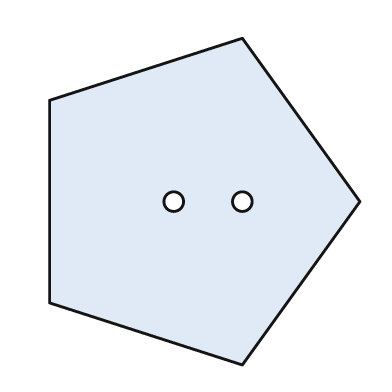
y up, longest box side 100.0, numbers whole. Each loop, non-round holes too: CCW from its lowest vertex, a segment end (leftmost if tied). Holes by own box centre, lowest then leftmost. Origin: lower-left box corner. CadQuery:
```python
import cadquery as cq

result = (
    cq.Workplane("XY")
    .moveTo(59.0, 0.0)
    .lineTo(95.0, 50.0)
    .lineTo(59.0, 100.0)
    .lineTo(0.0, 81.0)
    .lineTo(0.0, 19.0)
    .close()
    .moveTo(38.0, 50.0)
    .circle(3.0)
    .moveTo(59.0, 50.0)
    .circle(3.0)
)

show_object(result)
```